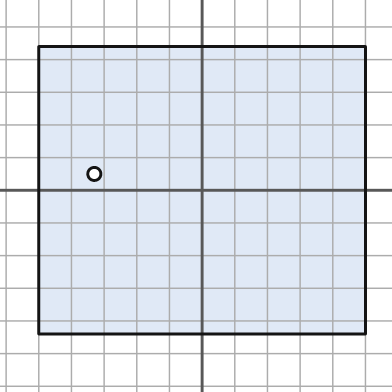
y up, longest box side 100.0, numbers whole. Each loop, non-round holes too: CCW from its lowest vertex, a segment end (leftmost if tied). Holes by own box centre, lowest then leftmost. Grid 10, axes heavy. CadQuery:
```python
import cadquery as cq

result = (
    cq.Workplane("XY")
    .moveTo(-50.0, -44.0)
    .lineTo(50.0, -44.0)
    .lineTo(50.0, 44.0)
    .lineTo(-50.0, 44.0)
    .close()
    .moveTo(-33.0, 5.0)
    .circle(2.0)
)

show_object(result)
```